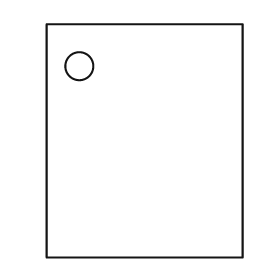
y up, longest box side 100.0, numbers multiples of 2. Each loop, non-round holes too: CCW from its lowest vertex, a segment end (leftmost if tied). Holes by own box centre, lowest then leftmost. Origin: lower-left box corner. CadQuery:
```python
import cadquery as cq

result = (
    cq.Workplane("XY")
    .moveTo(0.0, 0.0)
    .lineTo(84.0, 0.0)
    .lineTo(84.0, 100.0)
    .lineTo(0.0, 100.0)
    .close()
    .moveTo(14.0, 82.0)
    .circle(6.0)
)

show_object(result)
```